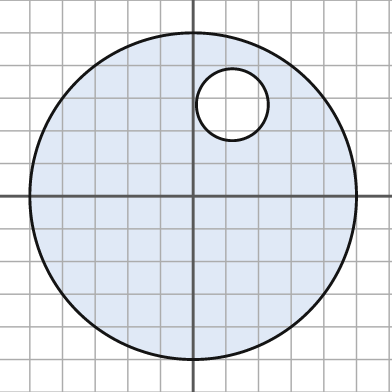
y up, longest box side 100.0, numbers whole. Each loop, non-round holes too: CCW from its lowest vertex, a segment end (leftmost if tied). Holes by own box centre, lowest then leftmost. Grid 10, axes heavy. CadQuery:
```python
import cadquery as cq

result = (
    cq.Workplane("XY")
    .moveTo(0.0, 0.0)
    .circle(50.0)
    .moveTo(12.0, 28.0)
    .circle(11.0)
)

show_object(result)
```